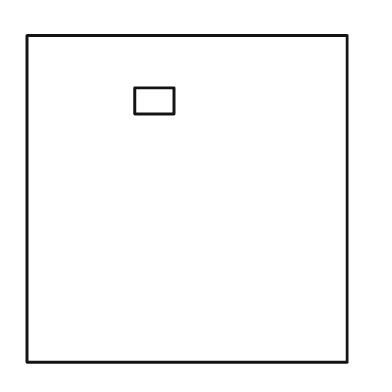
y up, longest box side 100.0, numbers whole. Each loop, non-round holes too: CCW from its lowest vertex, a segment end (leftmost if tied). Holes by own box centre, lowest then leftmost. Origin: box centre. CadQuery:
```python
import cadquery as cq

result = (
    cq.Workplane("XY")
    .moveTo(-49.0, -50.0)
    .lineTo(49.0, -50.0)
    .lineTo(49.0, 50.0)
    .lineTo(-49.0, 50.0)
    .close()
    .moveTo(-16.0, 26.0)
    .lineTo(-4.0, 26.0)
    .lineTo(-4.0, 34.0)
    .lineTo(-16.0, 34.0)
    .close()
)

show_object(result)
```